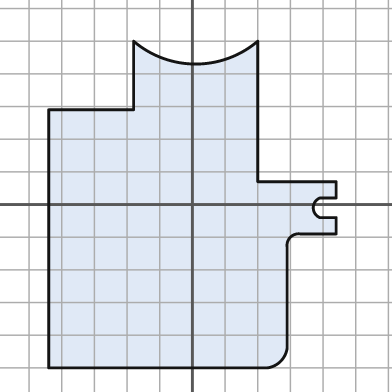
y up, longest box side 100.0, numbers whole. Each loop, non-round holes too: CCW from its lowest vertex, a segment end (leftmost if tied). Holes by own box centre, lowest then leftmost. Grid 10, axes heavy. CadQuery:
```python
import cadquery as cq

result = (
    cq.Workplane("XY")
    .moveTo(-44.0, -50.0)
    .lineTo(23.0, -50.0)
    .threePointArc((27.0, -48.0), (29.0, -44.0))
    .lineTo(29.0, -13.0)
    .threePointArc((30.0, -10.0), (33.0, -9.0))
    .lineTo(44.0, -9.0)
    .lineTo(44.0, -4.0)
    .lineTo(39.0, -4.0)
    .threePointArc((37.0, -1.0), (39.0, 2.0))
    .lineTo(44.0, 2.0)
    .lineTo(44.0, 7.0)
    .lineTo(20.0, 7.0)
    .lineTo(20.0, 50.0)
    .threePointArc((1.0, 43.0), (-18.0, 50.0))
    .lineTo(-18.0, 29.0)
    .lineTo(-44.0, 29.0)
    .close()
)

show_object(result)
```